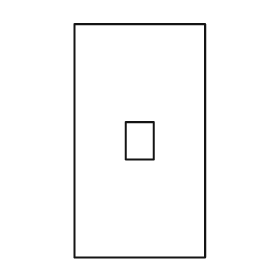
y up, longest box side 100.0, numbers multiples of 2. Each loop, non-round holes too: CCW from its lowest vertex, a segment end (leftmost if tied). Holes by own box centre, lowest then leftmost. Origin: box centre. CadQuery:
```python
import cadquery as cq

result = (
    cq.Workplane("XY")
    .moveTo(-28.0, -50.0)
    .lineTo(28.0, -50.0)
    .lineTo(28.0, 50.0)
    .lineTo(-28.0, 50.0)
    .close()
    .moveTo(-6.0, -8.0)
    .lineTo(6.0, -8.0)
    .lineTo(6.0, 8.0)
    .lineTo(-6.0, 8.0)
    .close()
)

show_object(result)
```